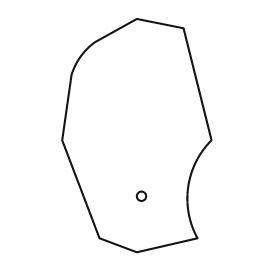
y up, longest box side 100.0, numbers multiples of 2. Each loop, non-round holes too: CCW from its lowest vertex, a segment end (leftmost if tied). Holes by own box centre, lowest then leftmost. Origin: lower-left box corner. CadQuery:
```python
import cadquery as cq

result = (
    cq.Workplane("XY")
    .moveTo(32.0, 0.0)
    .lineTo(58.0, 6.0)
    .threePointArc((54.0, 28.0), (64.0, 48.0))
    .lineTo(52.0, 96.0)
    .lineTo(32.0, 100.0)
    .lineTo(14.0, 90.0)
    .threePointArc((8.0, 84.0), (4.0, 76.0))
    .lineTo(0.0, 48.0)
    .lineTo(16.0, 6.0)
    .close()
    .moveTo(34.0, 24.0)
    .circle(2.0)
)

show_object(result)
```